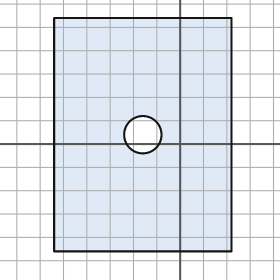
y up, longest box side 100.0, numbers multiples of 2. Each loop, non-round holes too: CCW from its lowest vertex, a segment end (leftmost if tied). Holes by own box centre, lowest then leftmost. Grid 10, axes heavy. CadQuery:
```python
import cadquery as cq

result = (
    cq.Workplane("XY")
    .moveTo(-54.0, -46.0)
    .lineTo(22.0, -46.0)
    .lineTo(22.0, 54.0)
    .lineTo(-54.0, 54.0)
    .close()
    .moveTo(-16.0, 4.0)
    .circle(8.0)
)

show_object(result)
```